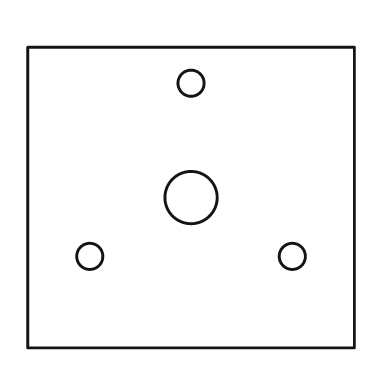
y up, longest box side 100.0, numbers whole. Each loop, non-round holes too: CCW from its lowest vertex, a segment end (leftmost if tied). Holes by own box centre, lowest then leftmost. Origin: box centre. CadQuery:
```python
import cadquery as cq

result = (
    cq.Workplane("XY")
    .moveTo(-50.0, -46.0)
    .lineTo(50.0, -46.0)
    .lineTo(50.0, 46.0)
    .lineTo(-50.0, 46.0)
    .close()
    .moveTo(-31.0, -18.0)
    .circle(4.0)
    .moveTo(31.0, -18.0)
    .circle(4.0)
    .moveTo(0.0, 0.0)
    .circle(8.0)
    .moveTo(0.0, 35.0)
    .circle(4.0)
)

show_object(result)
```